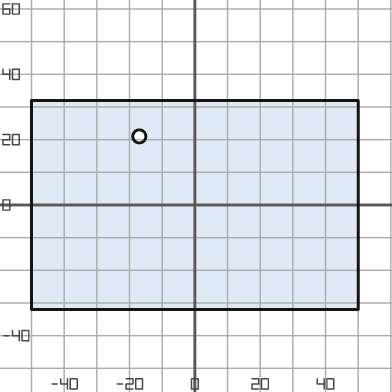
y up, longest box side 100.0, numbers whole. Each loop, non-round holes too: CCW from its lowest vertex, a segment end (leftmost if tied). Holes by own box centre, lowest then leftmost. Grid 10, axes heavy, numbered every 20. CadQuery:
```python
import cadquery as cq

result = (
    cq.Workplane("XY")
    .moveTo(-50.0, -32.0)
    .lineTo(50.0, -32.0)
    .lineTo(50.0, 32.0)
    .lineTo(-50.0, 32.0)
    .close()
    .moveTo(-17.0, 21.0)
    .circle(2.0)
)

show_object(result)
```